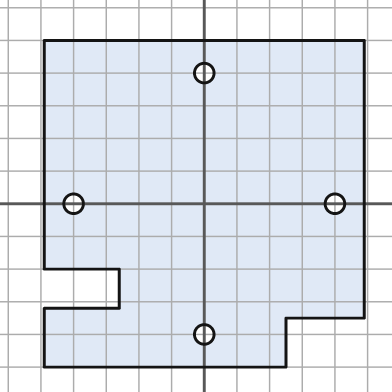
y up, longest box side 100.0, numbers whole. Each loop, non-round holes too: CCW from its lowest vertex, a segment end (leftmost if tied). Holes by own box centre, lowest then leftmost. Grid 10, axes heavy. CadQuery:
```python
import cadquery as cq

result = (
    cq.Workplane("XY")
    .moveTo(-49.0, -50.0)
    .lineTo(25.0, -50.0)
    .lineTo(25.0, -35.0)
    .lineTo(49.0, -35.0)
    .lineTo(49.0, 50.0)
    .lineTo(-49.0, 50.0)
    .lineTo(-49.0, -20.0)
    .lineTo(-26.0, -20.0)
    .lineTo(-26.0, -32.0)
    .lineTo(-49.0, -32.0)
    .close()
    .moveTo(0.0, -40.0)
    .circle(3.0)
    .moveTo(-40.0, 0.0)
    .circle(3.0)
    .moveTo(40.0, 0.0)
    .circle(3.0)
    .moveTo(0.0, 40.0)
    .circle(3.0)
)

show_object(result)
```